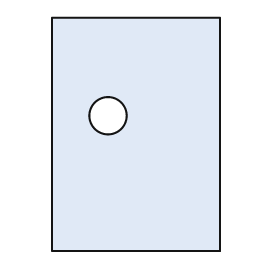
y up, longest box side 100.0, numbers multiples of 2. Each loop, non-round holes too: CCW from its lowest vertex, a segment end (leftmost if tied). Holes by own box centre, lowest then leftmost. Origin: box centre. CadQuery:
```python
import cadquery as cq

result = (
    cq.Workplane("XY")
    .moveTo(-36.0, -50.0)
    .lineTo(36.0, -50.0)
    .lineTo(36.0, 50.0)
    .lineTo(-36.0, 50.0)
    .close()
    .moveTo(-12.0, 8.0)
    .circle(8.0)
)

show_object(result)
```